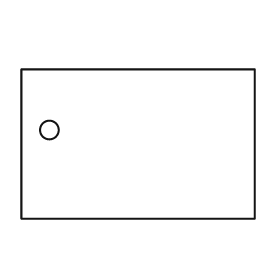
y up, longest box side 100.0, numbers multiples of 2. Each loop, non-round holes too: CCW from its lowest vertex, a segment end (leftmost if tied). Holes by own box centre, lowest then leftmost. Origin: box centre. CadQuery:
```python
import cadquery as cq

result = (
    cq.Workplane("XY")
    .moveTo(-50.0, -32.0)
    .lineTo(50.0, -32.0)
    .lineTo(50.0, 32.0)
    .lineTo(-50.0, 32.0)
    .close()
    .moveTo(-38.0, 6.0)
    .circle(4.0)
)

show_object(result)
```